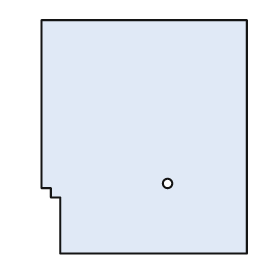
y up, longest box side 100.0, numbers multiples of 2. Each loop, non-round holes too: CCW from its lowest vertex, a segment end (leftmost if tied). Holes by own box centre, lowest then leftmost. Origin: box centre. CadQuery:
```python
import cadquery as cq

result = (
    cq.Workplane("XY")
    .moveTo(-36.0, -50.0)
    .lineTo(44.0, -50.0)
    .lineTo(44.0, 50.0)
    .lineTo(-44.0, 50.0)
    .lineTo(-44.0, -22.0)
    .lineTo(-40.0, -22.0)
    .lineTo(-40.0, -26.0)
    .lineTo(-36.0, -26.0)
    .close()
    .moveTo(10.0, -20.0)
    .circle(2.0)
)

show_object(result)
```